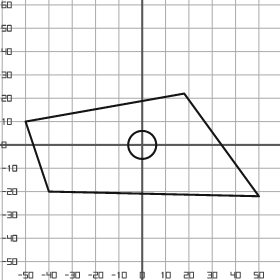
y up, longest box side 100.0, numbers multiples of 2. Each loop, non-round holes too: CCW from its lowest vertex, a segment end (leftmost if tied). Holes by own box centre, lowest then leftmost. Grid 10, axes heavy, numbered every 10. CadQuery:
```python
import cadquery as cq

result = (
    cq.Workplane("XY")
    .moveTo(50.0, -22.0)
    .lineTo(18.0, 22.0)
    .lineTo(-50.0, 10.0)
    .lineTo(-40.0, -20.0)
    .close()
    .moveTo(0.0, 0.0)
    .circle(6.0)
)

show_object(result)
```